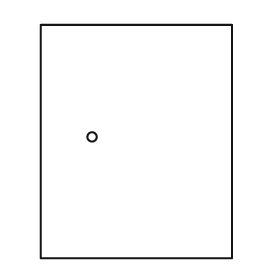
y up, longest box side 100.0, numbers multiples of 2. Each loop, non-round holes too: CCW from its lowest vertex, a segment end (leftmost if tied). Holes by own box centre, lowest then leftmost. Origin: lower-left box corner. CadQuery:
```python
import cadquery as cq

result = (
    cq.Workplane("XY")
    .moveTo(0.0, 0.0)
    .lineTo(82.0, 0.0)
    .lineTo(82.0, 100.0)
    .lineTo(0.0, 100.0)
    .close()
    .moveTo(22.0, 52.0)
    .circle(2.0)
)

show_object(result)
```